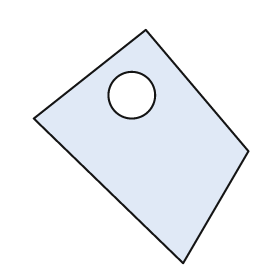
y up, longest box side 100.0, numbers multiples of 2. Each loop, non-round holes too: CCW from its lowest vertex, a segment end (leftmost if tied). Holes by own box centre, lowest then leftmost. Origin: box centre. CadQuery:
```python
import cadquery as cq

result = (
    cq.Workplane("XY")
    .moveTo(18.0, -50.0)
    .lineTo(46.0, -2.0)
    .lineTo(2.0, 50.0)
    .lineTo(-46.0, 12.0)
    .close()
    .moveTo(-4.0, 22.0)
    .circle(10.0)
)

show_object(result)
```